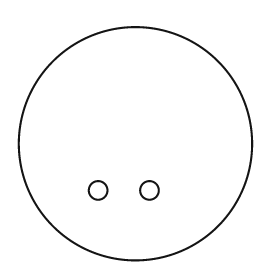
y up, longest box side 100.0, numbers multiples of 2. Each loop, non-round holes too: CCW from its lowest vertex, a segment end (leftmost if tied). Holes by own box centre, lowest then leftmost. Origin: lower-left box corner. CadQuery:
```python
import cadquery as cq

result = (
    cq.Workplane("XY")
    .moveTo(50.0, 50.0)
    .circle(50.0)
    .moveTo(34.0, 30.0)
    .circle(4.0)
    .moveTo(56.0, 30.0)
    .circle(4.0)
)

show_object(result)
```